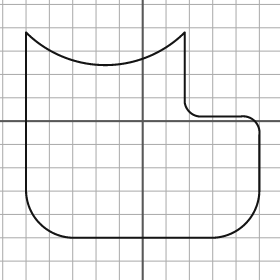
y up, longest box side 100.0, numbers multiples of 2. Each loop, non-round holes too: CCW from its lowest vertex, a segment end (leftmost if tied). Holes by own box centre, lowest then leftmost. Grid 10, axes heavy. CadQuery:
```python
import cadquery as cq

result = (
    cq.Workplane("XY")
    .moveTo(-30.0, -50.0)
    .lineTo(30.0, -50.0)
    .threePointArc((44.0, -44.0), (50.0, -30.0))
    .lineTo(50.0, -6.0)
    .threePointArc((48.0, 0.0), (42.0, 2.0))
    .lineTo(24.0, 2.0)
    .threePointArc((20.0, 4.0), (18.0, 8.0))
    .lineTo(18.0, 38.0)
    .threePointArc((-16.0, 24.0), (-50.0, 38.0))
    .lineTo(-50.0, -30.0)
    .threePointArc((-44.0, -44.0), (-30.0, -50.0))
    .close()
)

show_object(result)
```